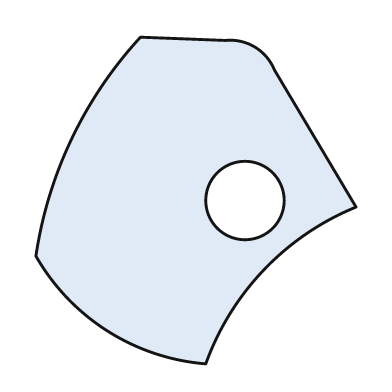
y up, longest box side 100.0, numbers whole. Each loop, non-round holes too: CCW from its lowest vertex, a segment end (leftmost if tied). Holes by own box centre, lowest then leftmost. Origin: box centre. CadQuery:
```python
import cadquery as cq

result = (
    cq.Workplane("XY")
    .moveTo(3.0, -50.0)
    .threePointArc((21.0, -21.0), (49.0, -2.0))
    .lineTo(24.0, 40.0)
    .threePointArc((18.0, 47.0), (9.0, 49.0))
    .lineTo(-17.0, 50.0)
    .threePointArc((-38.0, 19.0), (-49.0, -17.0))
    .threePointArc((-27.0, -40.0), (3.0, -50.0))
    .close()
    .moveTo(15.0, 0.0)
    .circle(12.0)
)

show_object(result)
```